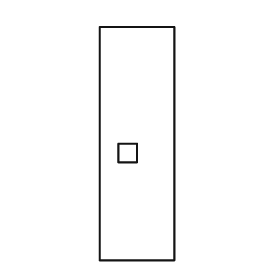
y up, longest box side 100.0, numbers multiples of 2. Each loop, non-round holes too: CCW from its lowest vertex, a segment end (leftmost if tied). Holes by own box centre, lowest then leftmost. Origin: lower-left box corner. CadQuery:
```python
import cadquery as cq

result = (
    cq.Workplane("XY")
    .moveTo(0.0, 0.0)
    .lineTo(32.0, 0.0)
    .lineTo(32.0, 100.0)
    .lineTo(0.0, 100.0)
    .close()
    .moveTo(8.0, 42.0)
    .lineTo(16.0, 42.0)
    .lineTo(16.0, 50.0)
    .lineTo(8.0, 50.0)
    .close()
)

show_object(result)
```